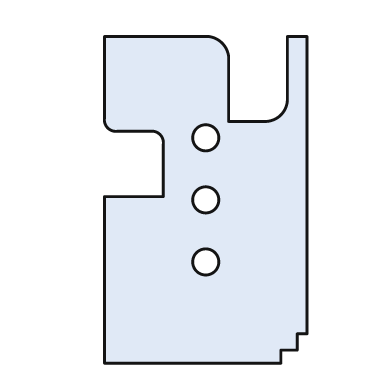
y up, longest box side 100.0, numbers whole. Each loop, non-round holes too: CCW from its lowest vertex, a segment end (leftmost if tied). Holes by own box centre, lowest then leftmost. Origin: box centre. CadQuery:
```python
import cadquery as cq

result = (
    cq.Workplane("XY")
    .moveTo(-31.0, -50.0)
    .lineTo(23.0, -50.0)
    .lineTo(23.0, -46.0)
    .lineTo(28.0, -46.0)
    .lineTo(28.0, -41.0)
    .lineTo(31.0, -41.0)
    .lineTo(31.0, 50.0)
    .lineTo(25.0, 50.0)
    .lineTo(25.0, 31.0)
    .threePointArc((23.0, 26.0), (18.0, 24.0))
    .lineTo(7.0, 24.0)
    .lineTo(7.0, 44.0)
    .threePointArc((5.0, 48.0), (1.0, 50.0))
    .lineTo(-31.0, 50.0)
    .lineTo(-31.0, 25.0)
    .threePointArc((-30.0, 22.0), (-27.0, 21.0))
    .lineTo(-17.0, 21.0)
    .threePointArc((-14.0, 20.0), (-13.0, 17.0))
    .lineTo(-13.0, 1.0)
    .lineTo(-31.0, 1.0)
    .close()
    .moveTo(0.0, -19.0)
    .circle(4.0)
    .moveTo(0.0, 0.0)
    .circle(4.0)
    .moveTo(0.0, 19.0)
    .circle(4.0)
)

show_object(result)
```